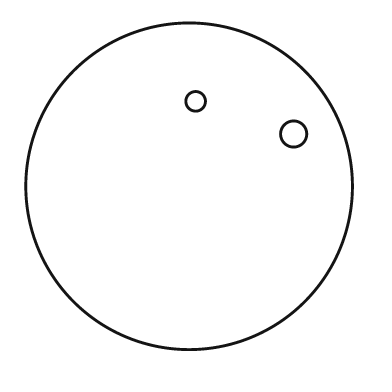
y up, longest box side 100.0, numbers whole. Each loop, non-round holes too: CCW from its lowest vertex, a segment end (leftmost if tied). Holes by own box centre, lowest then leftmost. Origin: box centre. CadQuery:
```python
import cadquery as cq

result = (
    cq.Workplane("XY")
    .moveTo(0.0, 0.0)
    .circle(50.0)
    .moveTo(32.0, 16.0)
    .circle(4.0)
    .moveTo(2.0, 26.0)
    .circle(3.0)
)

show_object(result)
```